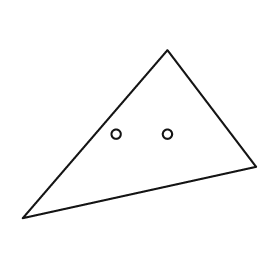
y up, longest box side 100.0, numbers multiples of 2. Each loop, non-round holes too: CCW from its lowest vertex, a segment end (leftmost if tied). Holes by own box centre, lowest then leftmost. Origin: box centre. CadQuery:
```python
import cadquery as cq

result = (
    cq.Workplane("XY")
    .moveTo(-50.0, -36.0)
    .lineTo(50.0, -14.0)
    .lineTo(12.0, 36.0)
    .close()
    .moveTo(-10.0, 0.0)
    .circle(2.0)
    .moveTo(12.0, 0.0)
    .circle(2.0)
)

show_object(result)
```